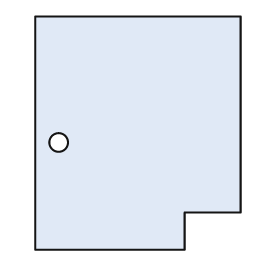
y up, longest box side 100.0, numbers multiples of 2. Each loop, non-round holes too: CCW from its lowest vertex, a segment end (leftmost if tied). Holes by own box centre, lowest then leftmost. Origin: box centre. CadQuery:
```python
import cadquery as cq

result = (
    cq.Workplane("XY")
    .moveTo(-44.0, -50.0)
    .lineTo(20.0, -50.0)
    .lineTo(20.0, -34.0)
    .lineTo(44.0, -34.0)
    .lineTo(44.0, 50.0)
    .lineTo(-44.0, 50.0)
    .close()
    .moveTo(-34.0, -4.0)
    .circle(4.0)
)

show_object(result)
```